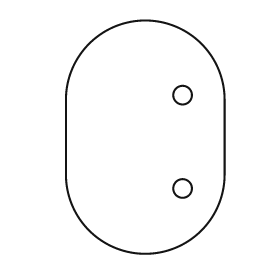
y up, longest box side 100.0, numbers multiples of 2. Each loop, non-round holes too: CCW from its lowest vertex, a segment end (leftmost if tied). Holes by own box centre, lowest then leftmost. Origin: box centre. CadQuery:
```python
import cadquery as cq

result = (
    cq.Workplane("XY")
    .moveTo(-34.0, -16.0)
    .threePointArc((0.0, -50.0), (34.0, -16.0))
    .lineTo(34.0, 16.0)
    .threePointArc((0.0, 50.0), (-34.0, 16.0))
    .close()
    .moveTo(16.0, -22.0)
    .circle(4.0)
    .moveTo(16.0, 18.0)
    .circle(4.0)
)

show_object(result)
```